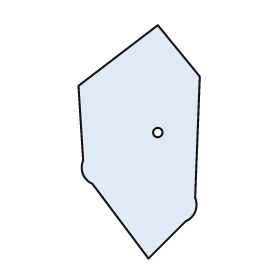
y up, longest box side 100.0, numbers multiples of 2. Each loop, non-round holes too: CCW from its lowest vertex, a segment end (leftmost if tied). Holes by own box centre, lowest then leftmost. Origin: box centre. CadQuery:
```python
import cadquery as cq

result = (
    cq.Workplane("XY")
    .moveTo(4.0, -50.0)
    .lineTo(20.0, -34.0)
    .threePointArc((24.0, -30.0), (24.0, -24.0))
    .lineTo(26.0, 28.0)
    .lineTo(8.0, 50.0)
    .lineTo(-26.0, 24.0)
    .lineTo(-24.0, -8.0)
    .threePointArc((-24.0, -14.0), (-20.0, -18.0))
    .close()
    .moveTo(8.0, 4.0)
    .circle(2.0)
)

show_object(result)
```